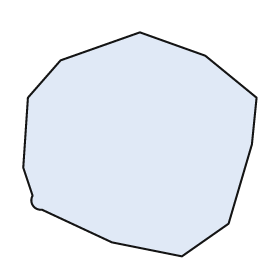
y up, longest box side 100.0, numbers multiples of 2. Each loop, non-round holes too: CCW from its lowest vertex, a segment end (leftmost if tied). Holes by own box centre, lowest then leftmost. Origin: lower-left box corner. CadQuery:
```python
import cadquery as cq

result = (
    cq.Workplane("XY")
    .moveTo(68.0, 0.0)
    .lineTo(88.0, 14.0)
    .lineTo(98.0, 48.0)
    .lineTo(100.0, 68.0)
    .lineTo(78.0, 86.0)
    .lineTo(50.0, 96.0)
    .lineTo(16.0, 84.0)
    .lineTo(2.0, 68.0)
    .lineTo(0.0, 38.0)
    .lineTo(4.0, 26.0)
    .threePointArc((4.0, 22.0), (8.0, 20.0))
    .lineTo(38.0, 6.0)
    .close()
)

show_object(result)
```